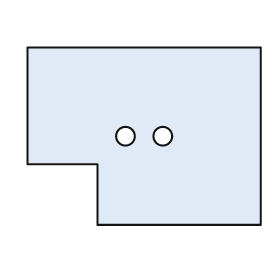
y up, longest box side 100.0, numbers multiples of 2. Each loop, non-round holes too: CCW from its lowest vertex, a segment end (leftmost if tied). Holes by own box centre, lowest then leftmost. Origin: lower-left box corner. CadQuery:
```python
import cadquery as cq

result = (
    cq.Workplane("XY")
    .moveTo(30.0, 0.0)
    .lineTo(100.0, 0.0)
    .lineTo(100.0, 76.0)
    .lineTo(0.0, 76.0)
    .lineTo(0.0, 26.0)
    .lineTo(30.0, 26.0)
    .close()
    .moveTo(42.0, 38.0)
    .circle(4.0)
    .moveTo(58.0, 38.0)
    .circle(4.0)
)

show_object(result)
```